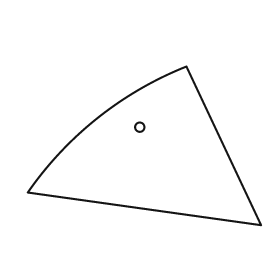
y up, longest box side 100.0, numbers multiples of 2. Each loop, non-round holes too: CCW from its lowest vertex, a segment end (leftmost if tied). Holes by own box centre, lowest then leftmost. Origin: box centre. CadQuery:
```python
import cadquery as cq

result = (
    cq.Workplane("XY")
    .moveTo(50.0, -34.0)
    .lineTo(18.0, 34.0)
    .threePointArc((-20.0, 12.0), (-50.0, -20.0))
    .close()
    .moveTo(-2.0, 8.0)
    .circle(2.0)
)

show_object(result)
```